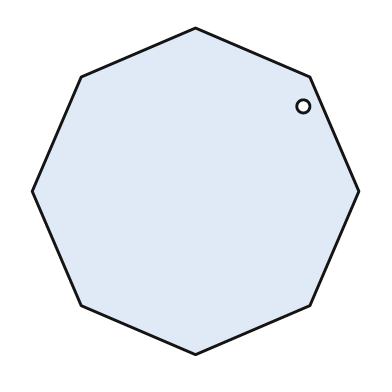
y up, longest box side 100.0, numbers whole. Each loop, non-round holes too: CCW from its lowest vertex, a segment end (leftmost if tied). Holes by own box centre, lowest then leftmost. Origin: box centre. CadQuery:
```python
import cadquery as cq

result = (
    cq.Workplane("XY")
    .moveTo(0.0, -50.0)
    .lineTo(35.0, -35.0)
    .lineTo(50.0, 0.0)
    .lineTo(35.0, 35.0)
    .lineTo(0.0, 50.0)
    .lineTo(-35.0, 35.0)
    .lineTo(-50.0, 0.0)
    .lineTo(-35.0, -35.0)
    .close()
    .moveTo(33.0, 26.0)
    .circle(2.0)
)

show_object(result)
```